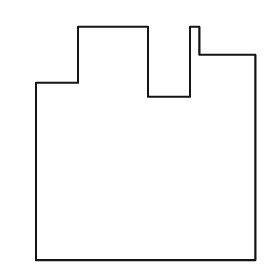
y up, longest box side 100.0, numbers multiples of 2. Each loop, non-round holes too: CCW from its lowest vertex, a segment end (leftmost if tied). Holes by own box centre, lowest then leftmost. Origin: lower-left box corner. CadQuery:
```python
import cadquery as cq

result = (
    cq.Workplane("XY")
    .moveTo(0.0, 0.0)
    .lineTo(94.0, 0.0)
    .lineTo(94.0, 88.0)
    .lineTo(70.0, 88.0)
    .lineTo(70.0, 100.0)
    .lineTo(66.0, 100.0)
    .lineTo(66.0, 70.0)
    .lineTo(48.0, 70.0)
    .lineTo(48.0, 100.0)
    .lineTo(18.0, 100.0)
    .lineTo(18.0, 76.0)
    .lineTo(0.0, 76.0)
    .close()
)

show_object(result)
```